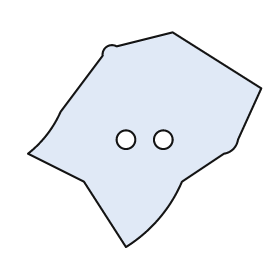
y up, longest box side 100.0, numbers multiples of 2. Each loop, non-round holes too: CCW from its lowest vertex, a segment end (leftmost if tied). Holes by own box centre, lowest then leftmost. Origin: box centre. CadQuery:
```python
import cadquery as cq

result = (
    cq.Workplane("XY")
    .moveTo(-8.0, -46.0)
    .threePointArc((6.0, -34.0), (16.0, -18.0))
    .lineTo(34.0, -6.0)
    .threePointArc((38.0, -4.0), (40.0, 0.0))
    .lineTo(50.0, 22.0)
    .lineTo(12.0, 46.0)
    .lineTo(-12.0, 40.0)
    .threePointArc((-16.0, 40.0), (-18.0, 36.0))
    .lineTo(-36.0, 12.0)
    .threePointArc((-42.0, 2.0), (-50.0, -6.0))
    .lineTo(-26.0, -18.0)
    .close()
    .moveTo(-8.0, 0.0)
    .circle(4.0)
    .moveTo(8.0, 0.0)
    .circle(4.0)
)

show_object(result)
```